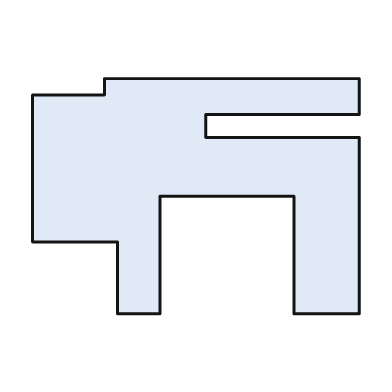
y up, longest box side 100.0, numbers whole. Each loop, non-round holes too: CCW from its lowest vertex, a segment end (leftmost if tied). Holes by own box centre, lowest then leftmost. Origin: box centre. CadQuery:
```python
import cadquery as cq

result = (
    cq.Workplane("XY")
    .moveTo(-24.0, -36.0)
    .lineTo(-11.0, -36.0)
    .lineTo(-11.0, 0.0)
    .lineTo(30.0, 0.0)
    .lineTo(30.0, -36.0)
    .lineTo(50.0, -36.0)
    .lineTo(50.0, 18.0)
    .lineTo(3.0, 18.0)
    .lineTo(3.0, 25.0)
    .lineTo(50.0, 25.0)
    .lineTo(50.0, 36.0)
    .lineTo(-28.0, 36.0)
    .lineTo(-28.0, 31.0)
    .lineTo(-50.0, 31.0)
    .lineTo(-50.0, -14.0)
    .lineTo(-24.0, -14.0)
    .close()
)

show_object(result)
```